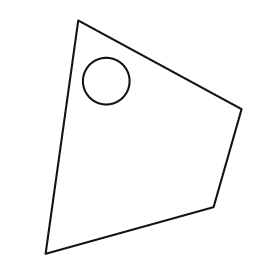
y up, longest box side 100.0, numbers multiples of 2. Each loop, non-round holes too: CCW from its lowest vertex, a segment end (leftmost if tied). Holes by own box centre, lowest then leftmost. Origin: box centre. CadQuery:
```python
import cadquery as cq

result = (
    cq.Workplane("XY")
    .moveTo(-42.0, -50.0)
    .lineTo(30.0, -30.0)
    .lineTo(42.0, 12.0)
    .lineTo(-28.0, 50.0)
    .close()
    .moveTo(-16.0, 24.0)
    .circle(10.0)
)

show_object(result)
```